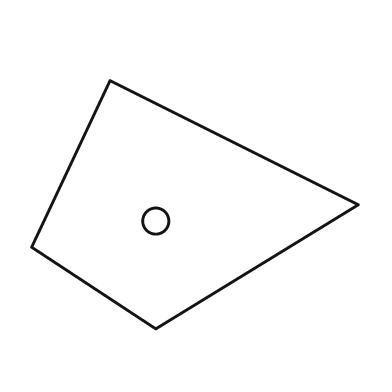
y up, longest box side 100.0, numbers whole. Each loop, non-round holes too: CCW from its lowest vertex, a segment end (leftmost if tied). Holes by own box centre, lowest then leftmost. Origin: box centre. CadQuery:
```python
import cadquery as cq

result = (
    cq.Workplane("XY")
    .moveTo(-12.0, -38.0)
    .lineTo(50.0, 0.0)
    .lineTo(-26.0, 38.0)
    .lineTo(-50.0, -13.0)
    .close()
    .moveTo(-12.0, -5.0)
    .circle(4.0)
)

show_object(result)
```